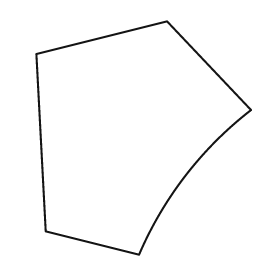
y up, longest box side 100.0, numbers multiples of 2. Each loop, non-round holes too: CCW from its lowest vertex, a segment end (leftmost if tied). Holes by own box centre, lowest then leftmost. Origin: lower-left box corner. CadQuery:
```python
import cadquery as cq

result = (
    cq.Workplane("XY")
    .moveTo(44.0, 0.0)
    .threePointArc((64.0, 34.0), (92.0, 62.0))
    .lineTo(56.0, 100.0)
    .lineTo(0.0, 86.0)
    .lineTo(4.0, 10.0)
    .close()
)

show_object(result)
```